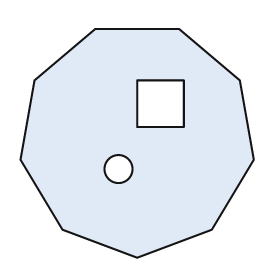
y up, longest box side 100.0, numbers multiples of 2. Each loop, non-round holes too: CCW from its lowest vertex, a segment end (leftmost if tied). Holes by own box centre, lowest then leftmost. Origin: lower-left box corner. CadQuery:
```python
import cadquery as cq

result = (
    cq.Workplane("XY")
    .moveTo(50.0, 0.0)
    .lineTo(82.0, 12.0)
    .lineTo(100.0, 42.0)
    .lineTo(94.0, 76.0)
    .lineTo(68.0, 98.0)
    .lineTo(32.0, 98.0)
    .lineTo(6.0, 76.0)
    .lineTo(0.0, 42.0)
    .lineTo(18.0, 12.0)
    .close()
    .moveTo(42.0, 38.0)
    .circle(6.0)
    .moveTo(50.0, 56.0)
    .lineTo(70.0, 56.0)
    .lineTo(70.0, 76.0)
    .lineTo(50.0, 76.0)
    .close()
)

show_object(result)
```